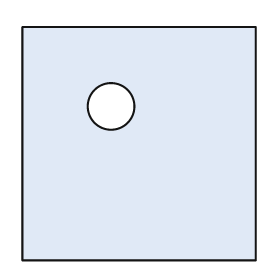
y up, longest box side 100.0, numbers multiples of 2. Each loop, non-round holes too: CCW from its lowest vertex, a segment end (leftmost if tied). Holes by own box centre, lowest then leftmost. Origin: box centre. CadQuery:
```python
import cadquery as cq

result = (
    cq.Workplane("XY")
    .moveTo(-50.0, -50.0)
    .lineTo(50.0, -50.0)
    .lineTo(50.0, 50.0)
    .lineTo(-50.0, 50.0)
    .close()
    .moveTo(-12.0, 16.0)
    .circle(10.0)
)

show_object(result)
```